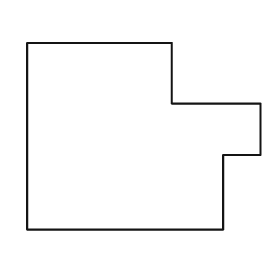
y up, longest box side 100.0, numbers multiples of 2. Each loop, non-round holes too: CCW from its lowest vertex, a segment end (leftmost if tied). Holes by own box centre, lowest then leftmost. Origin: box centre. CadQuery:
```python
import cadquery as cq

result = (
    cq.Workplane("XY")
    .moveTo(-50.0, -40.0)
    .lineTo(34.0, -40.0)
    .lineTo(34.0, -8.0)
    .lineTo(50.0, -8.0)
    .lineTo(50.0, 14.0)
    .lineTo(12.0, 14.0)
    .lineTo(12.0, 40.0)
    .lineTo(-50.0, 40.0)
    .close()
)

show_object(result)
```